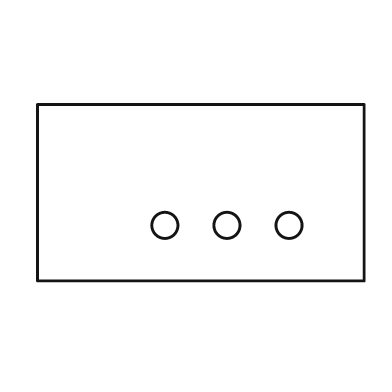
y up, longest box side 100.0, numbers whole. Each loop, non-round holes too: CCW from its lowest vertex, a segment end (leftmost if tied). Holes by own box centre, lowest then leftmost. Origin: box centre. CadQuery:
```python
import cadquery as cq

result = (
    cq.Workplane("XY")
    .moveTo(-50.0, -27.0)
    .lineTo(50.0, -27.0)
    .lineTo(50.0, 27.0)
    .lineTo(-50.0, 27.0)
    .close()
    .moveTo(-11.0, -10.0)
    .circle(4.0)
    .moveTo(8.0, -10.0)
    .circle(4.0)
    .moveTo(27.0, -10.0)
    .circle(4.0)
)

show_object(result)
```